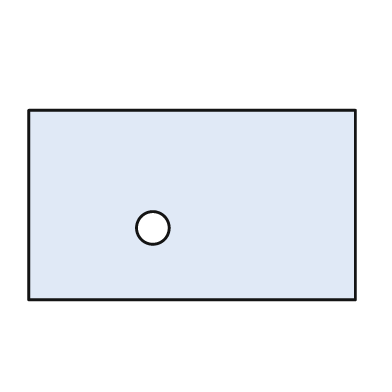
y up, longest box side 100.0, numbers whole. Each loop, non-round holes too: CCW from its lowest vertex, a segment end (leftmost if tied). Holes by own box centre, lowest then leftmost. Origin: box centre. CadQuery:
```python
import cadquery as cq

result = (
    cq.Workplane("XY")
    .moveTo(-50.0, -29.0)
    .lineTo(50.0, -29.0)
    .lineTo(50.0, 29.0)
    .lineTo(-50.0, 29.0)
    .close()
    .moveTo(-12.0, -7.0)
    .circle(5.0)
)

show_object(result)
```